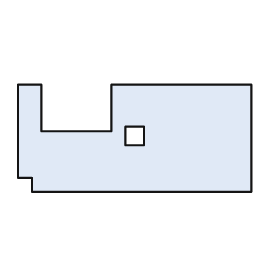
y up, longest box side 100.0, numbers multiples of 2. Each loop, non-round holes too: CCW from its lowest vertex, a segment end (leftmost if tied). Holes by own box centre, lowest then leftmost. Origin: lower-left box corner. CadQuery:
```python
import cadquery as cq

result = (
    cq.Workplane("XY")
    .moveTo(6.0, 0.0)
    .lineTo(100.0, 0.0)
    .lineTo(100.0, 46.0)
    .lineTo(40.0, 46.0)
    .lineTo(40.0, 26.0)
    .lineTo(10.0, 26.0)
    .lineTo(10.0, 46.0)
    .lineTo(0.0, 46.0)
    .lineTo(0.0, 6.0)
    .lineTo(6.0, 6.0)
    .close()
    .moveTo(46.0, 20.0)
    .lineTo(54.0, 20.0)
    .lineTo(54.0, 28.0)
    .lineTo(46.0, 28.0)
    .close()
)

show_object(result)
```